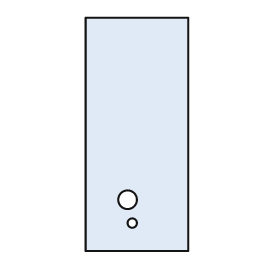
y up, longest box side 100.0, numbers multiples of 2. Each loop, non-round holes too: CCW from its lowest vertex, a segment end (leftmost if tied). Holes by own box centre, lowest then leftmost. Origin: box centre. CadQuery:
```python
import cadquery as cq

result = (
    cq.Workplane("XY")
    .moveTo(-22.0, -50.0)
    .lineTo(22.0, -50.0)
    .lineTo(22.0, 50.0)
    .lineTo(-22.0, 50.0)
    .close()
    .moveTo(-2.0, -38.0)
    .circle(2.0)
    .moveTo(-4.0, -28.0)
    .circle(4.0)
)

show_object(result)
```